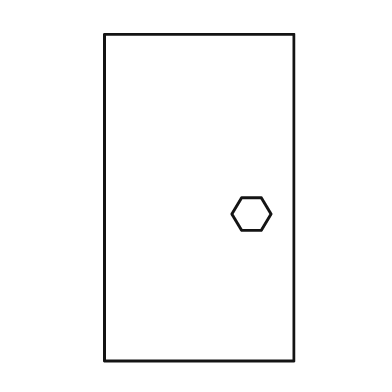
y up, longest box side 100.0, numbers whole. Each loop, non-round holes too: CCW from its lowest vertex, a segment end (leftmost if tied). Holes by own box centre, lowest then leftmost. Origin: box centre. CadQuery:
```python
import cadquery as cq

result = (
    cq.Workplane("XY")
    .moveTo(-29.0, -50.0)
    .lineTo(29.0, -50.0)
    .lineTo(29.0, 50.0)
    .lineTo(-29.0, 50.0)
    .close()
    .moveTo(13.0, -10.0)
    .lineTo(19.0, -10.0)
    .lineTo(22.0, -5.0)
    .lineTo(19.0, 0.0)
    .lineTo(13.0, 0.0)
    .lineTo(10.0, -5.0)
    .close()
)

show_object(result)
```